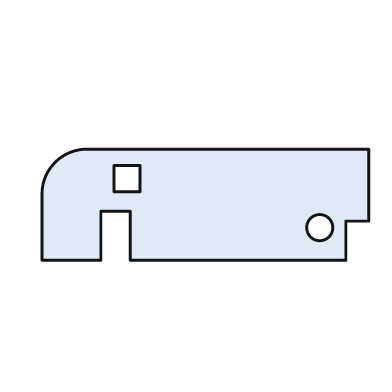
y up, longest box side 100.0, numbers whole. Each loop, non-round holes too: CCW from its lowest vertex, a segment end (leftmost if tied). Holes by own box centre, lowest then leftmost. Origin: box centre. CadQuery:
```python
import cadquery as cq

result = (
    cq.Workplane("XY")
    .moveTo(-50.0, -17.0)
    .lineTo(-32.0, -17.0)
    .lineTo(-32.0, -2.0)
    .lineTo(-23.0, -2.0)
    .lineTo(-23.0, -17.0)
    .lineTo(43.0, -17.0)
    .lineTo(43.0, -5.0)
    .lineTo(50.0, -5.0)
    .lineTo(50.0, 17.0)
    .lineTo(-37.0, 17.0)
    .threePointArc((-46.0, 13.0), (-50.0, 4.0))
    .close()
    .moveTo(35.0, -7.0)
    .circle(4.0)
    .moveTo(-28.0, 4.0)
    .lineTo(-20.0, 4.0)
    .lineTo(-20.0, 12.0)
    .lineTo(-28.0, 12.0)
    .close()
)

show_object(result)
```